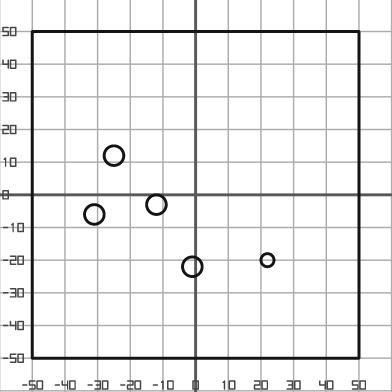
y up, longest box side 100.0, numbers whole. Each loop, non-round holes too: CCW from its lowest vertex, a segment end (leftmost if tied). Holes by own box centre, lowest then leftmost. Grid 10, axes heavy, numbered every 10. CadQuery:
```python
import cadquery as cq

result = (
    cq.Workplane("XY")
    .moveTo(-50.0, -50.0)
    .lineTo(50.0, -50.0)
    .lineTo(50.0, 50.0)
    .lineTo(-50.0, 50.0)
    .close()
    .moveTo(-1.0, -22.0)
    .circle(3.0)
    .moveTo(22.0, -20.0)
    .circle(2.0)
    .moveTo(-31.0, -6.0)
    .circle(3.0)
    .moveTo(-12.0, -3.0)
    .circle(3.0)
    .moveTo(-25.0, 12.0)
    .circle(3.0)
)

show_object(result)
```